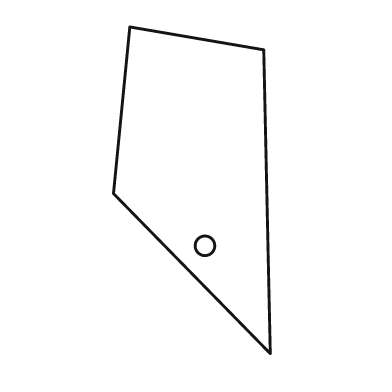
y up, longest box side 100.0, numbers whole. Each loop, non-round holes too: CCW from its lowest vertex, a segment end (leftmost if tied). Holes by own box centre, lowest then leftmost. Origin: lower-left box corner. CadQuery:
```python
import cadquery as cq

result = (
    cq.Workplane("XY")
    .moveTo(48.0, 0.0)
    .lineTo(46.0, 93.0)
    .lineTo(5.0, 100.0)
    .lineTo(0.0, 49.0)
    .close()
    .moveTo(28.0, 33.0)
    .circle(3.0)
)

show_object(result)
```